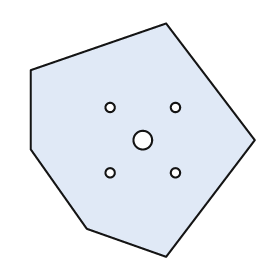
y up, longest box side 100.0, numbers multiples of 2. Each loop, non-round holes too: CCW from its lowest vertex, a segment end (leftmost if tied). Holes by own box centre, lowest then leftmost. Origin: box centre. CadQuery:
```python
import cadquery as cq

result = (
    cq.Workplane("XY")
    .moveTo(10.0, -50.0)
    .lineTo(48.0, 0.0)
    .lineTo(10.0, 50.0)
    .lineTo(-48.0, 30.0)
    .lineTo(-48.0, -4.0)
    .lineTo(-24.0, -38.0)
    .close()
    .moveTo(-14.0, -14.0)
    .circle(2.0)
    .moveTo(14.0, -14.0)
    .circle(2.0)
    .moveTo(0.0, 0.0)
    .circle(4.0)
    .moveTo(-14.0, 14.0)
    .circle(2.0)
    .moveTo(14.0, 14.0)
    .circle(2.0)
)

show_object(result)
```